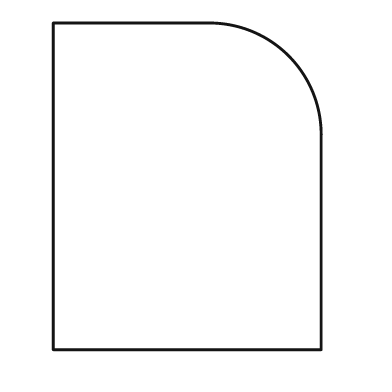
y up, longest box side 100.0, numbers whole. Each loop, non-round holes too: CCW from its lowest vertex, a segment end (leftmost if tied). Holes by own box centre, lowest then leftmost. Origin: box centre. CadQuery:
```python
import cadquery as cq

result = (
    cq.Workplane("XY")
    .moveTo(-41.0, -50.0)
    .lineTo(41.0, -50.0)
    .lineTo(41.0, 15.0)
    .threePointArc((31.0, 40.0), (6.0, 50.0))
    .lineTo(-41.0, 50.0)
    .close()
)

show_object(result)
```